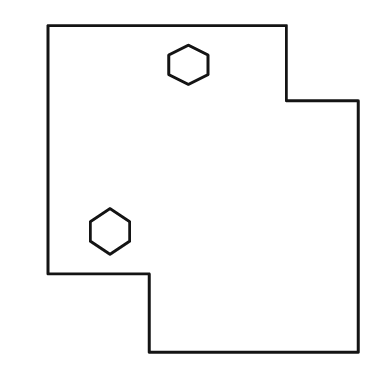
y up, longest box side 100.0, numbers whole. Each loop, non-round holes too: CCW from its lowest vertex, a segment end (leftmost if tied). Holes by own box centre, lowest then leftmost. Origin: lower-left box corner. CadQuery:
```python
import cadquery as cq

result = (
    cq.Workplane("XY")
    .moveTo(31.0, 0.0)
    .lineTo(95.0, 0.0)
    .lineTo(95.0, 77.0)
    .lineTo(73.0, 77.0)
    .lineTo(73.0, 100.0)
    .lineTo(0.0, 100.0)
    .lineTo(0.0, 24.0)
    .lineTo(31.0, 24.0)
    .close()
    .moveTo(19.0, 30.0)
    .lineTo(25.0, 34.0)
    .lineTo(25.0, 40.0)
    .lineTo(19.0, 44.0)
    .lineTo(13.0, 40.0)
    .lineTo(13.0, 34.0)
    .close()
    .moveTo(43.0, 82.0)
    .lineTo(49.0, 85.0)
    .lineTo(49.0, 91.0)
    .lineTo(43.0, 94.0)
    .lineTo(37.0, 91.0)
    .lineTo(37.0, 85.0)
    .close()
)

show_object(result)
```